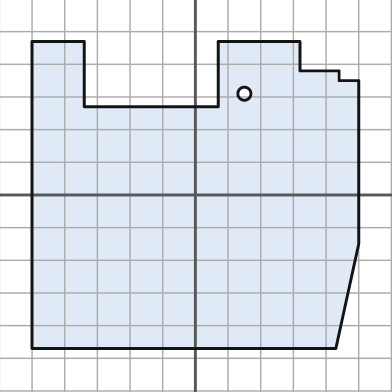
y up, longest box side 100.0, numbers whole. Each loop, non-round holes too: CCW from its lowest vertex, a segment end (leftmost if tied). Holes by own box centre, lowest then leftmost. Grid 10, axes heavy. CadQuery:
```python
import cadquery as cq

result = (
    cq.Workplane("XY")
    .moveTo(-50.0, -47.0)
    .lineTo(43.0, -47.0)
    .lineTo(50.0, -15.0)
    .lineTo(50.0, 35.0)
    .lineTo(44.0, 35.0)
    .lineTo(44.0, 38.0)
    .lineTo(32.0, 38.0)
    .lineTo(32.0, 47.0)
    .lineTo(7.0, 47.0)
    .lineTo(7.0, 27.0)
    .lineTo(-34.0, 27.0)
    .lineTo(-34.0, 47.0)
    .lineTo(-50.0, 47.0)
    .close()
    .moveTo(15.0, 31.0)
    .circle(2.0)
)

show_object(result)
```